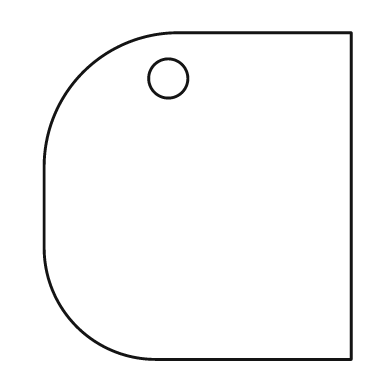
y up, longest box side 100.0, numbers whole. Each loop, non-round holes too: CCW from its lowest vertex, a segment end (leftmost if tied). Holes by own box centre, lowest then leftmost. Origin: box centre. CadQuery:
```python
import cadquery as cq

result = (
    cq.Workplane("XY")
    .moveTo(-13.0, -50.0)
    .lineTo(47.0, -50.0)
    .lineTo(47.0, 50.0)
    .lineTo(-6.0, 50.0)
    .threePointArc((-35.0, 38.0), (-47.0, 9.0))
    .lineTo(-47.0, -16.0)
    .threePointArc((-37.0, -40.0), (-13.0, -50.0))
    .close()
    .moveTo(-9.0, 36.0)
    .circle(6.0)
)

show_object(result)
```